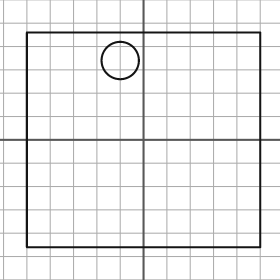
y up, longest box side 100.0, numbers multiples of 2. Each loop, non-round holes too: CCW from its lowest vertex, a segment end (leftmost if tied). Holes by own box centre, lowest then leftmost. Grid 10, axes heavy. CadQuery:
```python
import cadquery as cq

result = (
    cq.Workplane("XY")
    .moveTo(-50.0, -46.0)
    .lineTo(50.0, -46.0)
    .lineTo(50.0, 46.0)
    .lineTo(-50.0, 46.0)
    .close()
    .moveTo(-10.0, 34.0)
    .circle(8.0)
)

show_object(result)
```